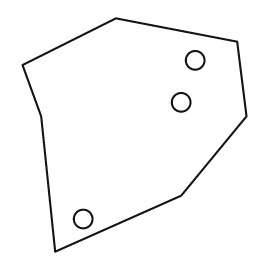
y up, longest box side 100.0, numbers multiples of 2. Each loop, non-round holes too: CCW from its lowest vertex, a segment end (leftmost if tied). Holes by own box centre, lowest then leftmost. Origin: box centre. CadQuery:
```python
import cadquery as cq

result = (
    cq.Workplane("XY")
    .moveTo(-34.0, -50.0)
    .lineTo(20.0, -26.0)
    .lineTo(48.0, 8.0)
    .lineTo(44.0, 40.0)
    .lineTo(-8.0, 50.0)
    .lineTo(-48.0, 30.0)
    .lineTo(-40.0, 8.0)
    .close()
    .moveTo(-22.0, -36.0)
    .circle(4.0)
    .moveTo(20.0, 14.0)
    .circle(4.0)
    .moveTo(26.0, 32.0)
    .circle(4.0)
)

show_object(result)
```